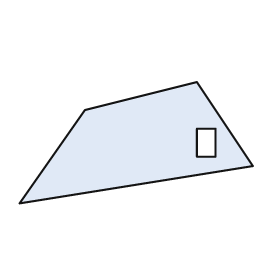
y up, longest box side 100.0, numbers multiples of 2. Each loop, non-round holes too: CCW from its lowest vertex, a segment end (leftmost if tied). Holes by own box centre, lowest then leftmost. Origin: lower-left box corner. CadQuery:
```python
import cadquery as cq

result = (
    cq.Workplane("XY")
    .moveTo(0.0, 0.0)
    .lineTo(100.0, 16.0)
    .lineTo(76.0, 52.0)
    .lineTo(28.0, 40.0)
    .close()
    .moveTo(76.0, 20.0)
    .lineTo(84.0, 20.0)
    .lineTo(84.0, 32.0)
    .lineTo(76.0, 32.0)
    .close()
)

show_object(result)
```